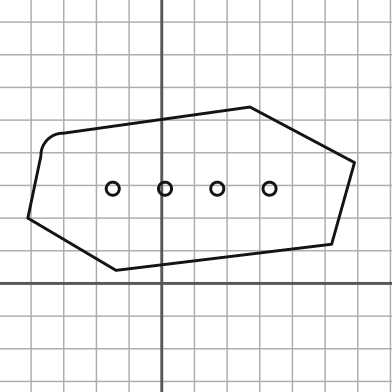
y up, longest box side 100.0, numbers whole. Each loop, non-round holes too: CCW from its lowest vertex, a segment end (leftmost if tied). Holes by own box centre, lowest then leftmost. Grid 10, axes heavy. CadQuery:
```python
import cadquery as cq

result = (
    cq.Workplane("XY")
    .moveTo(-14.0, 4.0)
    .lineTo(52.0, 12.0)
    .lineTo(59.0, 37.0)
    .lineTo(27.0, 54.0)
    .lineTo(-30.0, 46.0)
    .threePointArc((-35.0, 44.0), (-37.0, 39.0))
    .lineTo(-41.0, 20.0)
    .close()
    .moveTo(-15.0, 29.0)
    .circle(2.0)
    .moveTo(1.0, 29.0)
    .circle(2.0)
    .moveTo(17.0, 29.0)
    .circle(2.0)
    .moveTo(33.0, 29.0)
    .circle(2.0)
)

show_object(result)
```